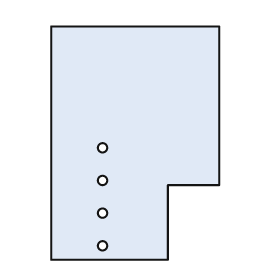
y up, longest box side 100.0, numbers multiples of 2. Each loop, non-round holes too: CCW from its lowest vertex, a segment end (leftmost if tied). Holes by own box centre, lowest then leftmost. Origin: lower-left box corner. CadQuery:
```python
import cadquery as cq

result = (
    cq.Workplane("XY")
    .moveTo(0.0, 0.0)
    .lineTo(50.0, 0.0)
    .lineTo(50.0, 32.0)
    .lineTo(72.0, 32.0)
    .lineTo(72.0, 100.0)
    .lineTo(0.0, 100.0)
    .close()
    .moveTo(22.0, 6.0)
    .circle(2.0)
    .moveTo(22.0, 20.0)
    .circle(2.0)
    .moveTo(22.0, 34.0)
    .circle(2.0)
    .moveTo(22.0, 48.0)
    .circle(2.0)
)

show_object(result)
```